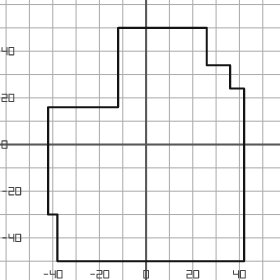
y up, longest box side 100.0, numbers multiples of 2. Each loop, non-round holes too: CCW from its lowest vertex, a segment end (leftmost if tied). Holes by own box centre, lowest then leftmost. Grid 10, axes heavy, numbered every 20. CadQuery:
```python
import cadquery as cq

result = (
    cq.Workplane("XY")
    .moveTo(-38.0, -50.0)
    .lineTo(42.0, -50.0)
    .lineTo(42.0, 24.0)
    .lineTo(36.0, 24.0)
    .lineTo(36.0, 34.0)
    .lineTo(26.0, 34.0)
    .lineTo(26.0, 50.0)
    .lineTo(-12.0, 50.0)
    .lineTo(-12.0, 16.0)
    .lineTo(-42.0, 16.0)
    .lineTo(-42.0, -30.0)
    .lineTo(-38.0, -30.0)
    .close()
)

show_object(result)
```